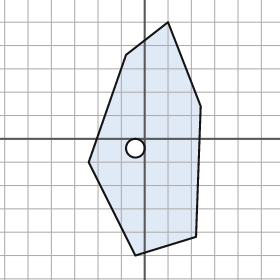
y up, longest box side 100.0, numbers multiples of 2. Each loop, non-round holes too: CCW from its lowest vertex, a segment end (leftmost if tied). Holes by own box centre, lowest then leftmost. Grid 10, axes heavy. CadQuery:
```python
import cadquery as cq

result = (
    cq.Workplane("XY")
    .moveTo(-4.0, -50.0)
    .lineTo(22.0, -42.0)
    .lineTo(24.0, 14.0)
    .lineTo(10.0, 50.0)
    .lineTo(-8.0, 36.0)
    .lineTo(-24.0, -10.0)
    .close()
    .moveTo(-4.0, -4.0)
    .circle(4.0)
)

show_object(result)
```